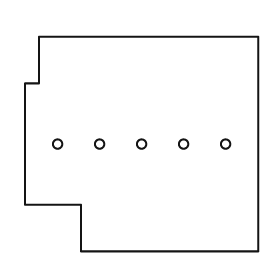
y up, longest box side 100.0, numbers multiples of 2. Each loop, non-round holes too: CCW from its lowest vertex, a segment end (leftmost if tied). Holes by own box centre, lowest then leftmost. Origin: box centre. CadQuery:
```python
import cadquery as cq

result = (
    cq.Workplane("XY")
    .moveTo(-26.0, -46.0)
    .lineTo(50.0, -46.0)
    .lineTo(50.0, 46.0)
    .lineTo(-44.0, 46.0)
    .lineTo(-44.0, 26.0)
    .lineTo(-50.0, 26.0)
    .lineTo(-50.0, -26.0)
    .lineTo(-26.0, -26.0)
    .close()
    .moveTo(-36.0, 0.0)
    .circle(2.0)
    .moveTo(-18.0, 0.0)
    .circle(2.0)
    .moveTo(0.0, 0.0)
    .circle(2.0)
    .moveTo(18.0, 0.0)
    .circle(2.0)
    .moveTo(36.0, 0.0)
    .circle(2.0)
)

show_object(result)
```